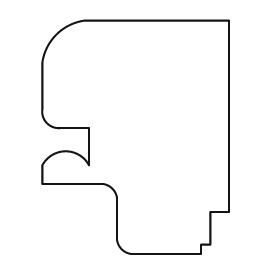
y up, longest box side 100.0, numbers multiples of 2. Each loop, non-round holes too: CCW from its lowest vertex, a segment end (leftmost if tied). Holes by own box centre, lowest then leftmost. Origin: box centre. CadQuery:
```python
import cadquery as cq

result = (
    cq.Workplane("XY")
    .moveTo(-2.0, -50.0)
    .lineTo(28.0, -50.0)
    .lineTo(28.0, -46.0)
    .lineTo(32.0, -46.0)
    .lineTo(32.0, -32.0)
    .lineTo(40.0, -32.0)
    .lineTo(40.0, 50.0)
    .lineTo(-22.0, 50.0)
    .threePointArc((-34.0, 44.0), (-40.0, 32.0))
    .lineTo(-40.0, 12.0)
    .threePointArc((-38.0, 6.0), (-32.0, 4.0))
    .lineTo(-20.0, 4.0)
    .lineTo(-20.0, -12.0)
    .threePointArc((-30.0, -6.0), (-40.0, -12.0))
    .lineTo(-40.0, -20.0)
    .lineTo(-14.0, -20.0)
    .threePointArc((-10.0, -22.0), (-8.0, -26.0))
    .lineTo(-8.0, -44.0)
    .threePointArc((-6.0, -48.0), (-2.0, -50.0))
    .close()
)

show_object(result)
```